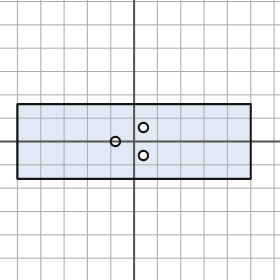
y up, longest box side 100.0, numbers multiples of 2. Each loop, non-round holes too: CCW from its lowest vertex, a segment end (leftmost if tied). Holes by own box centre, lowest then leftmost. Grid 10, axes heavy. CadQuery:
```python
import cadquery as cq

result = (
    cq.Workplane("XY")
    .moveTo(-50.0, -16.0)
    .lineTo(50.0, -16.0)
    .lineTo(50.0, 16.0)
    .lineTo(-50.0, 16.0)
    .close()
    .moveTo(4.0, -6.0)
    .circle(2.0)
    .moveTo(-8.0, 0.0)
    .circle(2.0)
    .moveTo(4.0, 6.0)
    .circle(2.0)
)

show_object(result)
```